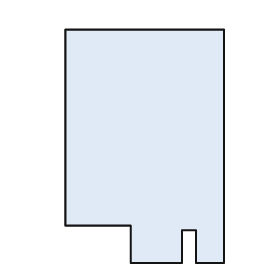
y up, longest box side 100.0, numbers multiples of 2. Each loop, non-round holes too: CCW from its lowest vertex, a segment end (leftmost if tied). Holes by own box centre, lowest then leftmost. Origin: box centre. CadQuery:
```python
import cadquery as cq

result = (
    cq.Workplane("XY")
    .moveTo(-6.0, -50.0)
    .lineTo(16.0, -50.0)
    .lineTo(16.0, -36.0)
    .lineTo(22.0, -36.0)
    .lineTo(22.0, -50.0)
    .lineTo(34.0, -50.0)
    .lineTo(34.0, 50.0)
    .lineTo(-34.0, 50.0)
    .lineTo(-34.0, -34.0)
    .lineTo(-6.0, -34.0)
    .close()
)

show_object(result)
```